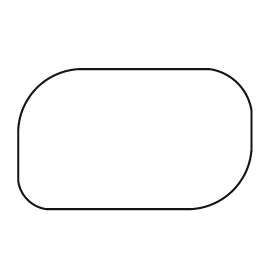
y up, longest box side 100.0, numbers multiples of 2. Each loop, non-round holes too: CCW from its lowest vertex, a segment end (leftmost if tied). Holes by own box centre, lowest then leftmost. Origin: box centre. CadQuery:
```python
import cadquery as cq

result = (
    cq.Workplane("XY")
    .moveTo(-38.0, -30.0)
    .lineTo(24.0, -30.0)
    .threePointArc((42.0, -22.0), (50.0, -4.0))
    .lineTo(50.0, 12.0)
    .threePointArc((44.0, 24.0), (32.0, 30.0))
    .lineTo(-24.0, 30.0)
    .threePointArc((-42.0, 22.0), (-50.0, 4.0))
    .lineTo(-50.0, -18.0)
    .threePointArc((-46.0, -26.0), (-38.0, -30.0))
    .close()
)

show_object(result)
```